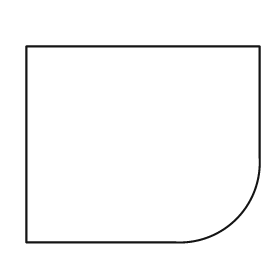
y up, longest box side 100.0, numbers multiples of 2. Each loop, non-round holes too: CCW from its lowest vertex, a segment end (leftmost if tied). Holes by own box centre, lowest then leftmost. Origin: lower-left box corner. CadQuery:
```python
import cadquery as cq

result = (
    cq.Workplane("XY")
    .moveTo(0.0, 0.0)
    .lineTo(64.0, 0.0)
    .threePointArc((90.0, 10.0), (100.0, 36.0))
    .lineTo(100.0, 84.0)
    .lineTo(0.0, 84.0)
    .close()
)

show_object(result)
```